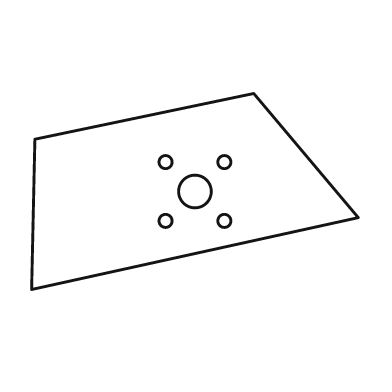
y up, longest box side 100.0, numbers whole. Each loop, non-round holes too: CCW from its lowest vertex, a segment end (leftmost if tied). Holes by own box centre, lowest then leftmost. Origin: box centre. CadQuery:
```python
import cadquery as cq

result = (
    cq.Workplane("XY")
    .moveTo(-50.0, -30.0)
    .lineTo(50.0, -8.0)
    .lineTo(18.0, 30.0)
    .lineTo(-49.0, 16.0)
    .close()
    .moveTo(-9.0, -9.0)
    .circle(2.0)
    .moveTo(9.0, -9.0)
    .circle(2.0)
    .moveTo(0.0, 0.0)
    .circle(5.0)
    .moveTo(-9.0, 9.0)
    .circle(2.0)
    .moveTo(9.0, 9.0)
    .circle(2.0)
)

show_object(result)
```